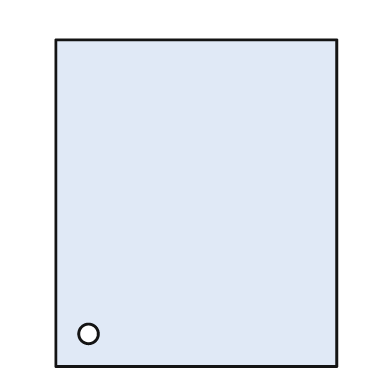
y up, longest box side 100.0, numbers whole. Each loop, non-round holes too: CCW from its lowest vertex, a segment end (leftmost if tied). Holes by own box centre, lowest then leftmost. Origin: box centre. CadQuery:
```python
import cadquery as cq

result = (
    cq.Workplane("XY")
    .moveTo(-43.0, -50.0)
    .lineTo(43.0, -50.0)
    .lineTo(43.0, 50.0)
    .lineTo(-43.0, 50.0)
    .close()
    .moveTo(-33.0, -40.0)
    .circle(3.0)
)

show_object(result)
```